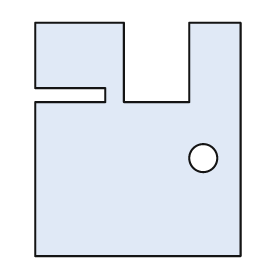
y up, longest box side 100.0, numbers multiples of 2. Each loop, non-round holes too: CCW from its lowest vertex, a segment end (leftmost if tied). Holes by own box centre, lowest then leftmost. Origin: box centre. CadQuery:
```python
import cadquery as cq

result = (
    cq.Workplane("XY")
    .moveTo(-44.0, -50.0)
    .lineTo(44.0, -50.0)
    .lineTo(44.0, 50.0)
    .lineTo(22.0, 50.0)
    .lineTo(22.0, 16.0)
    .lineTo(-6.0, 16.0)
    .lineTo(-6.0, 50.0)
    .lineTo(-44.0, 50.0)
    .lineTo(-44.0, 22.0)
    .lineTo(-14.0, 22.0)
    .lineTo(-14.0, 16.0)
    .lineTo(-44.0, 16.0)
    .close()
    .moveTo(28.0, -8.0)
    .circle(6.0)
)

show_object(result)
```